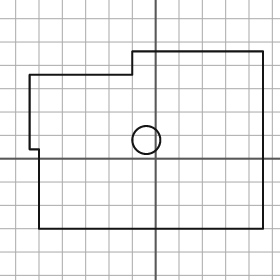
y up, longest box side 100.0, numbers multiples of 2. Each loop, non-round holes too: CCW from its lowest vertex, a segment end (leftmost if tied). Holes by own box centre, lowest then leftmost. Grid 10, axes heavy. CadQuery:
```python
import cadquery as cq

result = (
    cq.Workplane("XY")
    .moveTo(-50.0, -30.0)
    .lineTo(46.0, -30.0)
    .lineTo(46.0, 46.0)
    .lineTo(-10.0, 46.0)
    .lineTo(-10.0, 36.0)
    .lineTo(-54.0, 36.0)
    .lineTo(-54.0, 4.0)
    .lineTo(-50.0, 4.0)
    .close()
    .moveTo(-4.0, 8.0)
    .circle(6.0)
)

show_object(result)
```